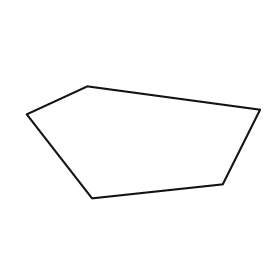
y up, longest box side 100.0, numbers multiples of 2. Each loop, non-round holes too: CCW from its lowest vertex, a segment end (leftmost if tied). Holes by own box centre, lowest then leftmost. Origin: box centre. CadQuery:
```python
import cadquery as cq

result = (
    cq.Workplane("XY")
    .moveTo(-22.0, -24.0)
    .lineTo(34.0, -18.0)
    .lineTo(50.0, 14.0)
    .lineTo(-24.0, 24.0)
    .lineTo(-50.0, 12.0)
    .close()
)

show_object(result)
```